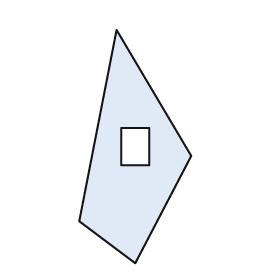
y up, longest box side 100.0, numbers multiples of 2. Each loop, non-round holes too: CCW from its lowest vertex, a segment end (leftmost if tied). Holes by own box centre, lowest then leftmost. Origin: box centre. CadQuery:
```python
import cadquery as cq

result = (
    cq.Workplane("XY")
    .moveTo(0.0, -50.0)
    .lineTo(24.0, -4.0)
    .lineTo(-8.0, 50.0)
    .lineTo(-24.0, -32.0)
    .close()
    .moveTo(-6.0, -8.0)
    .lineTo(6.0, -8.0)
    .lineTo(6.0, 8.0)
    .lineTo(-6.0, 8.0)
    .close()
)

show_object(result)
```